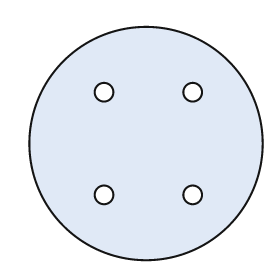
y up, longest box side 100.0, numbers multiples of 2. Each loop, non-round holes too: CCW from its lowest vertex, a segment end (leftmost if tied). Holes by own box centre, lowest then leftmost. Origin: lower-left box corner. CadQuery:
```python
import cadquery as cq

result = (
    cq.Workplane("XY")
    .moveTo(50.0, 50.0)
    .circle(50.0)
    .moveTo(32.0, 28.0)
    .circle(4.0)
    .moveTo(70.0, 28.0)
    .circle(4.0)
    .moveTo(32.0, 72.0)
    .circle(4.0)
    .moveTo(70.0, 72.0)
    .circle(4.0)
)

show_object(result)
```